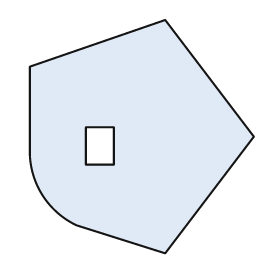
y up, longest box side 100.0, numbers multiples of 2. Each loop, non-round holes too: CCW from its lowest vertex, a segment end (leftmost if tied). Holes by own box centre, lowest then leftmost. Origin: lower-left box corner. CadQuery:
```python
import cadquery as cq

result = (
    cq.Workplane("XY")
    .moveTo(58.0, 0.0)
    .lineTo(96.0, 50.0)
    .lineTo(58.0, 100.0)
    .lineTo(0.0, 80.0)
    .lineTo(0.0, 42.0)
    .threePointArc((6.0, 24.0), (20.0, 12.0))
    .close()
    .moveTo(24.0, 38.0)
    .lineTo(36.0, 38.0)
    .lineTo(36.0, 54.0)
    .lineTo(24.0, 54.0)
    .close()
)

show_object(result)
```